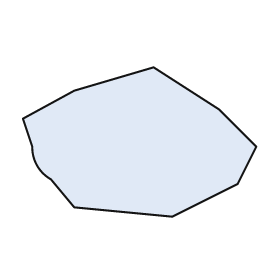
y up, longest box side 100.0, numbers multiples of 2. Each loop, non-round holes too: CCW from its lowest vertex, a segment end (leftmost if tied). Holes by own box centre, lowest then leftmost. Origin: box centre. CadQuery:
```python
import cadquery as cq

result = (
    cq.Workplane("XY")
    .moveTo(14.0, -32.0)
    .lineTo(42.0, -18.0)
    .lineTo(50.0, -2.0)
    .lineTo(34.0, 14.0)
    .lineTo(6.0, 32.0)
    .lineTo(-28.0, 22.0)
    .lineTo(-50.0, 10.0)
    .lineTo(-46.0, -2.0)
    .threePointArc((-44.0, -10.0), (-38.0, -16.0))
    .lineTo(-28.0, -28.0)
    .close()
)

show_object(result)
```